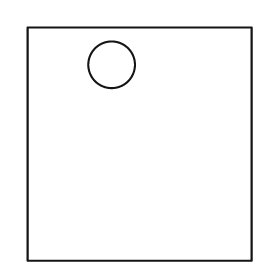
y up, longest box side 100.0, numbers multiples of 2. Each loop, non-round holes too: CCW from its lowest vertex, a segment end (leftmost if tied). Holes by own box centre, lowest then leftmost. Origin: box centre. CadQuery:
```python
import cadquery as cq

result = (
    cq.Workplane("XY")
    .moveTo(-48.0, -50.0)
    .lineTo(48.0, -50.0)
    .lineTo(48.0, 50.0)
    .lineTo(-48.0, 50.0)
    .close()
    .moveTo(-12.0, 34.0)
    .circle(10.0)
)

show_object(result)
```